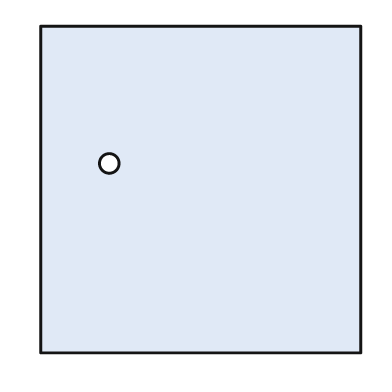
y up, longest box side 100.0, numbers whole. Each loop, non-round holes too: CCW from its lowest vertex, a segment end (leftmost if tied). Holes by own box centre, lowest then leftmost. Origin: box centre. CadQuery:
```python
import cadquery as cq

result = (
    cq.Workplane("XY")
    .moveTo(-49.0, -50.0)
    .lineTo(49.0, -50.0)
    .lineTo(49.0, 50.0)
    .lineTo(-49.0, 50.0)
    .close()
    .moveTo(-28.0, 8.0)
    .circle(3.0)
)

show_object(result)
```